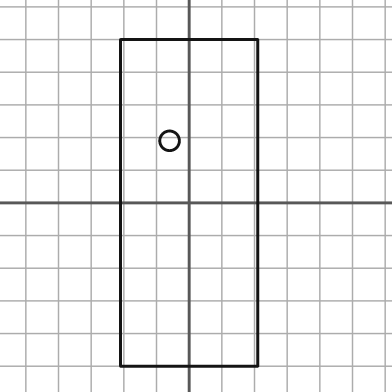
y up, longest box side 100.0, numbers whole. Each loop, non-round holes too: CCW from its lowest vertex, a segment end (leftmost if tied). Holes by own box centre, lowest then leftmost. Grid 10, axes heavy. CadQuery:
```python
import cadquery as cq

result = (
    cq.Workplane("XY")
    .moveTo(-21.0, -50.0)
    .lineTo(21.0, -50.0)
    .lineTo(21.0, 50.0)
    .lineTo(-21.0, 50.0)
    .close()
    .moveTo(-6.0, 19.0)
    .circle(3.0)
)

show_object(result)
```